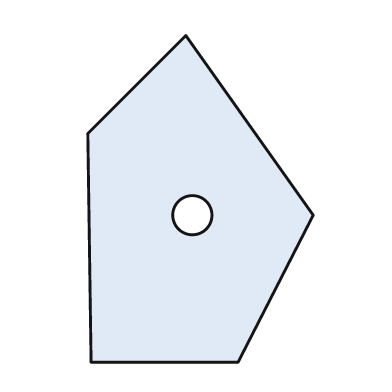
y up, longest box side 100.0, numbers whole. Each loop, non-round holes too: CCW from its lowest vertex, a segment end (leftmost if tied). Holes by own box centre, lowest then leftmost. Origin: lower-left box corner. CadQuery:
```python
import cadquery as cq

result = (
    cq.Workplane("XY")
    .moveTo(1.0, 0.0)
    .lineTo(46.0, 0.0)
    .lineTo(69.0, 45.0)
    .lineTo(30.0, 100.0)
    .lineTo(0.0, 70.0)
    .close()
    .moveTo(32.0, 45.0)
    .circle(6.0)
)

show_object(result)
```